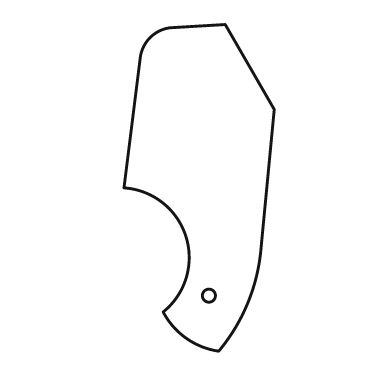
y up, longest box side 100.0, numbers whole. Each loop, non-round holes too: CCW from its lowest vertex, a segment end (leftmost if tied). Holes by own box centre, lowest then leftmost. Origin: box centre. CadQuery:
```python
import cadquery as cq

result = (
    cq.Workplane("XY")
    .moveTo(6.0, -50.0)
    .threePointArc((15.0, -35.0), (19.0, -18.0))
    .lineTo(23.0, 24.0)
    .lineTo(8.0, 50.0)
    .lineTo(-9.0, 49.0)
    .threePointArc((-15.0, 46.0), (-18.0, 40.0))
    .lineTo(-23.0, 0.0)
    .threePointArc((-4.0, -15.0), (-11.0, -38.0))
    .threePointArc((-4.0, -46.0), (6.0, -50.0))
    .close()
    .moveTo(3.0, -33.0)
    .circle(2.0)
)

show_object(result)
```